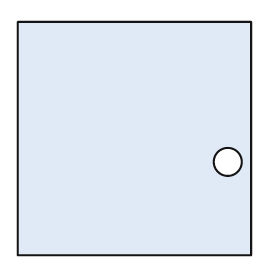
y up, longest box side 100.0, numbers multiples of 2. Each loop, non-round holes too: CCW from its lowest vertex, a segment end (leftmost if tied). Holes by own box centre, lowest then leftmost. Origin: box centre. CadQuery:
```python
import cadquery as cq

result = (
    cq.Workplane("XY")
    .moveTo(-50.0, -50.0)
    .lineTo(50.0, -50.0)
    .lineTo(50.0, 50.0)
    .lineTo(-50.0, 50.0)
    .close()
    .moveTo(40.0, -10.0)
    .circle(6.0)
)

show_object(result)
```